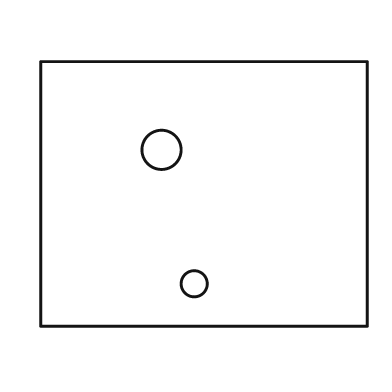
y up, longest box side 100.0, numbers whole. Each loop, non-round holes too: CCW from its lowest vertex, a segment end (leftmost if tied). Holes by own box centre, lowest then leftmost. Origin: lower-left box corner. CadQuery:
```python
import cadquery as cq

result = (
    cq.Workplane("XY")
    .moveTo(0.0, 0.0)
    .lineTo(100.0, 0.0)
    .lineTo(100.0, 81.0)
    .lineTo(0.0, 81.0)
    .close()
    .moveTo(47.0, 13.0)
    .circle(4.0)
    .moveTo(37.0, 54.0)
    .circle(6.0)
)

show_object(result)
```